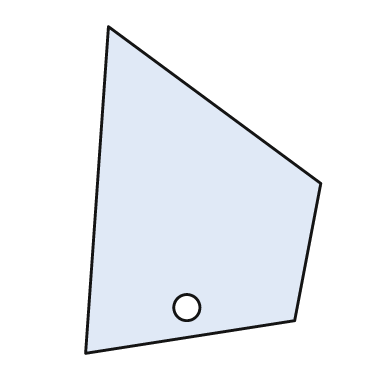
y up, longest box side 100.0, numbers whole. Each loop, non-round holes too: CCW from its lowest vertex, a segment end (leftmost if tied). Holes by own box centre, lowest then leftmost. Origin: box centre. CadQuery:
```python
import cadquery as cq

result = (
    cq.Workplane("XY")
    .moveTo(-36.0, -50.0)
    .lineTo(28.0, -40.0)
    .lineTo(36.0, 2.0)
    .lineTo(-29.0, 50.0)
    .close()
    .moveTo(-5.0, -36.0)
    .circle(4.0)
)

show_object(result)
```